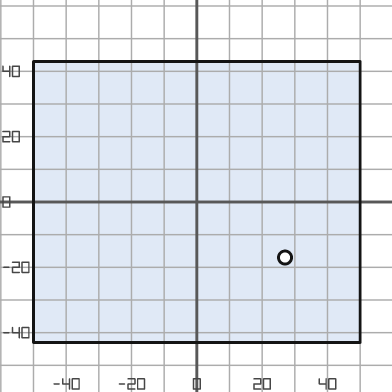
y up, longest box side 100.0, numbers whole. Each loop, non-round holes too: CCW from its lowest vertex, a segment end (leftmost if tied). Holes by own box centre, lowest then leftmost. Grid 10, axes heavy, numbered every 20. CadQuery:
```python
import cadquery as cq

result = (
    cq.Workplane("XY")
    .moveTo(-50.0, -43.0)
    .lineTo(50.0, -43.0)
    .lineTo(50.0, 43.0)
    .lineTo(-50.0, 43.0)
    .close()
    .moveTo(27.0, -17.0)
    .circle(2.0)
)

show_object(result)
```